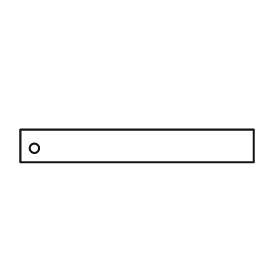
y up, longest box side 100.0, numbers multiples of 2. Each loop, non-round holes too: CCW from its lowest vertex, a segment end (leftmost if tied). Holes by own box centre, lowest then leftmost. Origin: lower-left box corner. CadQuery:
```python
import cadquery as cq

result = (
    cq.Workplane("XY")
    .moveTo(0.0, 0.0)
    .lineTo(100.0, 0.0)
    .lineTo(100.0, 14.0)
    .lineTo(0.0, 14.0)
    .close()
    .moveTo(6.0, 6.0)
    .circle(2.0)
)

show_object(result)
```